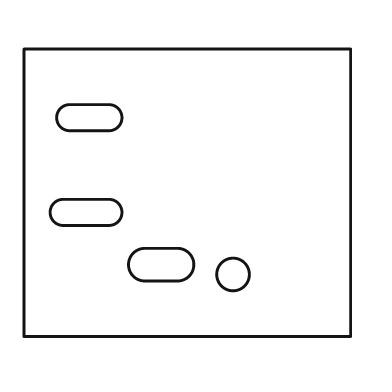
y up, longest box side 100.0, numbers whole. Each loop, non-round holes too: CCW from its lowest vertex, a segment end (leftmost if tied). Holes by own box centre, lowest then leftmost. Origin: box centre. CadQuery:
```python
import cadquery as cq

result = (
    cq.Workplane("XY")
    .moveTo(-50.0, -44.0)
    .lineTo(50.0, -44.0)
    .lineTo(50.0, 44.0)
    .lineTo(-50.0, 44.0)
    .close()
    .moveTo(14.0, -25.0)
    .circle(5.0)
    .moveTo(-13.0, -27.0)
    .lineTo(-3.0, -27.0)
    .threePointArc((2.0, -22.0), (-3.0, -17.0))
    .lineTo(-13.0, -17.0)
    .threePointArc((-18.0, -22.0), (-13.0, -27.0))
    .close()
    .moveTo(-38.0, -10.0)
    .lineTo(-24.0, -10.0)
    .threePointArc((-20.0, -6.0), (-24.0, -2.0))
    .lineTo(-38.0, -2.0)
    .threePointArc((-42.0, -6.0), (-38.0, -10.0))
    .close()
    .moveTo(-36.0, 19.0)
    .lineTo(-24.0, 19.0)
    .threePointArc((-20.0, 23.0), (-24.0, 27.0))
    .lineTo(-36.0, 27.0)
    .threePointArc((-40.0, 23.0), (-36.0, 19.0))
    .close()
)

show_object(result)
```